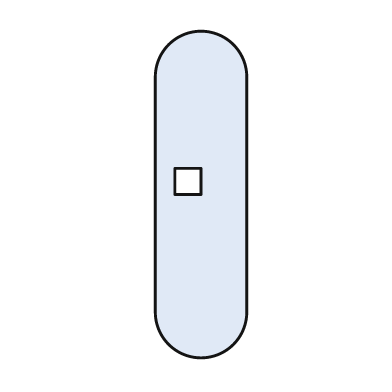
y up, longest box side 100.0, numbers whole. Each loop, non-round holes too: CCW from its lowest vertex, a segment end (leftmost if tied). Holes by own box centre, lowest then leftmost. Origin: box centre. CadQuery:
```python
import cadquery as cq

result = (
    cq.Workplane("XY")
    .moveTo(-14.0, -36.0)
    .threePointArc((0.0, -50.0), (14.0, -36.0))
    .lineTo(14.0, 36.0)
    .threePointArc((0.0, 50.0), (-14.0, 36.0))
    .close()
    .moveTo(-8.0, 0.0)
    .lineTo(0.0, 0.0)
    .lineTo(0.0, 8.0)
    .lineTo(-8.0, 8.0)
    .close()
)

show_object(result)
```